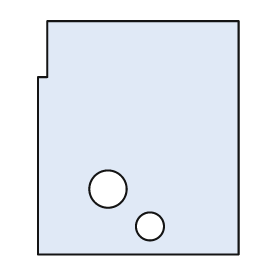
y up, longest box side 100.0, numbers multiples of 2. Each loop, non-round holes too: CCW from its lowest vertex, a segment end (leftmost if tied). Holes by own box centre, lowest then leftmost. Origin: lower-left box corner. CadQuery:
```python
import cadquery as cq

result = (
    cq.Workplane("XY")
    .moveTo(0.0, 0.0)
    .lineTo(86.0, 0.0)
    .lineTo(86.0, 100.0)
    .lineTo(4.0, 100.0)
    .lineTo(4.0, 76.0)
    .lineTo(0.0, 76.0)
    .close()
    .moveTo(48.0, 12.0)
    .circle(6.0)
    .moveTo(30.0, 28.0)
    .circle(8.0)
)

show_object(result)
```